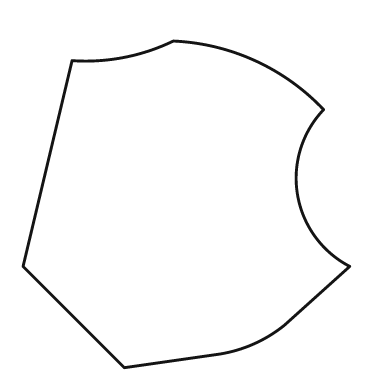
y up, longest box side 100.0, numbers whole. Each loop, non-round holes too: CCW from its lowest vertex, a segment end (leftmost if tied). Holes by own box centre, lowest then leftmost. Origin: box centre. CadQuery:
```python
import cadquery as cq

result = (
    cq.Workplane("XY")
    .moveTo(-19.0, -50.0)
    .lineTo(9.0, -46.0)
    .threePointArc((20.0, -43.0), (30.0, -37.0))
    .lineTo(50.0, -19.0)
    .threePointArc((34.0, 3.0), (42.0, 29.0))
    .threePointArc((21.0, 44.0), (-4.0, 50.0))
    .threePointArc((-19.0, 45.0), (-35.0, 44.0))
    .lineTo(-50.0, -19.0)
    .close()
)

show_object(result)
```